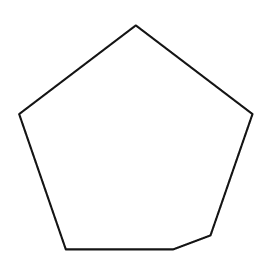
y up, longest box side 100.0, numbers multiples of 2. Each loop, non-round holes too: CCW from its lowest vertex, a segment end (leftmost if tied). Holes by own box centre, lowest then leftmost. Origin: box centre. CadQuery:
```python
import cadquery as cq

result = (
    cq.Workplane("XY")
    .moveTo(-30.0, -48.0)
    .lineTo(16.0, -48.0)
    .lineTo(32.0, -42.0)
    .lineTo(50.0, 10.0)
    .lineTo(0.0, 48.0)
    .lineTo(-50.0, 10.0)
    .close()
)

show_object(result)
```